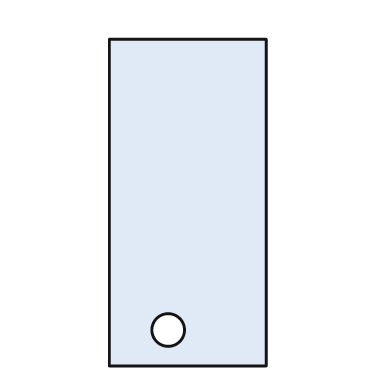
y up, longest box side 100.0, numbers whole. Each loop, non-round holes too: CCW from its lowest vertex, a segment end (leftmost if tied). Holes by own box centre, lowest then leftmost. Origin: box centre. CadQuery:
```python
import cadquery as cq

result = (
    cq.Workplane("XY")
    .moveTo(-24.0, -50.0)
    .lineTo(24.0, -50.0)
    .lineTo(24.0, 50.0)
    .lineTo(-24.0, 50.0)
    .close()
    .moveTo(-6.0, -39.0)
    .circle(5.0)
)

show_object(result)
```